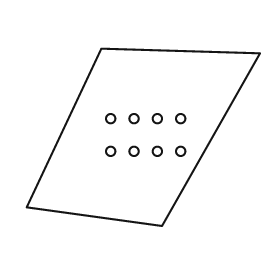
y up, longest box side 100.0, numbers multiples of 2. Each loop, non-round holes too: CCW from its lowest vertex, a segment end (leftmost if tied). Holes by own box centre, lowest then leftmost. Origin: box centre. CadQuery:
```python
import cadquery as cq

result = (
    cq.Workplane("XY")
    .moveTo(8.0, -38.0)
    .lineTo(50.0, 36.0)
    .lineTo(-18.0, 38.0)
    .lineTo(-50.0, -30.0)
    .close()
    .moveTo(-14.0, -6.0)
    .circle(2.0)
    .moveTo(-4.0, -6.0)
    .circle(2.0)
    .moveTo(6.0, -6.0)
    .circle(2.0)
    .moveTo(16.0, -6.0)
    .circle(2.0)
    .moveTo(-14.0, 8.0)
    .circle(2.0)
    .moveTo(-4.0, 8.0)
    .circle(2.0)
    .moveTo(6.0, 8.0)
    .circle(2.0)
    .moveTo(16.0, 8.0)
    .circle(2.0)
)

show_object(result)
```